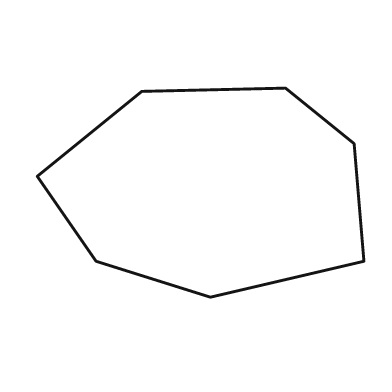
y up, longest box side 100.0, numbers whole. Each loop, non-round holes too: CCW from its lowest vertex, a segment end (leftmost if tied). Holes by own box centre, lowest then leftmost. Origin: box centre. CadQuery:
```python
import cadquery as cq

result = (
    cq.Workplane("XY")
    .moveTo(3.0, -32.0)
    .lineTo(50.0, -21.0)
    .lineTo(47.0, 15.0)
    .lineTo(26.0, 32.0)
    .lineTo(-18.0, 31.0)
    .lineTo(-50.0, 5.0)
    .lineTo(-32.0, -21.0)
    .close()
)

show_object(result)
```